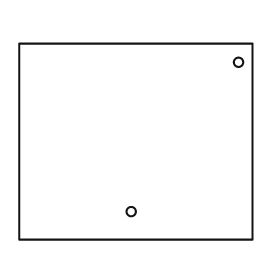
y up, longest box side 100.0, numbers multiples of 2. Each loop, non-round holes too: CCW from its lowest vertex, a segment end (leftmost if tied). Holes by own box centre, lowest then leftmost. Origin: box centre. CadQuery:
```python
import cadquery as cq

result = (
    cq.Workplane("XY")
    .moveTo(-50.0, -42.0)
    .lineTo(50.0, -42.0)
    .lineTo(50.0, 42.0)
    .lineTo(-50.0, 42.0)
    .close()
    .moveTo(-2.0, -30.0)
    .circle(2.0)
    .moveTo(44.0, 34.0)
    .circle(2.0)
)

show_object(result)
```